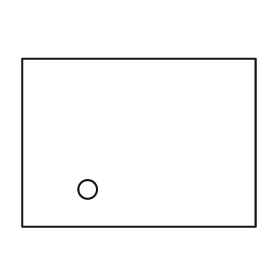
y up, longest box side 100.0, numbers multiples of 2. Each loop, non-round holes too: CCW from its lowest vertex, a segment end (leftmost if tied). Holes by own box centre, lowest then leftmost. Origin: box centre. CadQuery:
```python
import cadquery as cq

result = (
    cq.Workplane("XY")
    .moveTo(-50.0, -36.0)
    .lineTo(50.0, -36.0)
    .lineTo(50.0, 36.0)
    .lineTo(-50.0, 36.0)
    .close()
    .moveTo(-22.0, -20.0)
    .circle(4.0)
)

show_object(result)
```